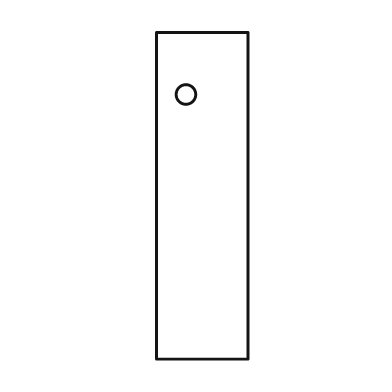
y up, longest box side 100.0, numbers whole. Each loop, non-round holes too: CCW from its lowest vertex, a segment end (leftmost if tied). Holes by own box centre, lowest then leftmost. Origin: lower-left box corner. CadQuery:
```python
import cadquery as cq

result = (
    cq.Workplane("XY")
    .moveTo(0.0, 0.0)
    .lineTo(28.0, 0.0)
    .lineTo(28.0, 100.0)
    .lineTo(0.0, 100.0)
    .close()
    .moveTo(9.0, 81.0)
    .circle(3.0)
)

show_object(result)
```